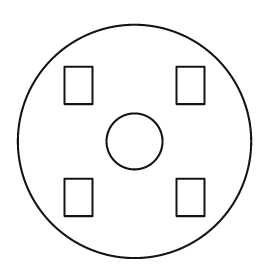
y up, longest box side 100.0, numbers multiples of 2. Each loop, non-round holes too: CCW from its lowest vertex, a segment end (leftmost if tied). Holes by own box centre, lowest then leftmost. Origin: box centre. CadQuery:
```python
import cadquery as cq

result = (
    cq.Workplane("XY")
    .moveTo(0.0, 0.0)
    .circle(50.0)
    .moveTo(-30.0, -32.0)
    .lineTo(-18.0, -32.0)
    .lineTo(-18.0, -16.0)
    .lineTo(-30.0, -16.0)
    .close()
    .moveTo(18.0, -32.0)
    .lineTo(30.0, -32.0)
    .lineTo(30.0, -16.0)
    .lineTo(18.0, -16.0)
    .close()
    .moveTo(0.0, 0.0)
    .circle(12.0)
    .moveTo(-30.0, 16.0)
    .lineTo(-18.0, 16.0)
    .lineTo(-18.0, 32.0)
    .lineTo(-30.0, 32.0)
    .close()
    .moveTo(18.0, 16.0)
    .lineTo(30.0, 16.0)
    .lineTo(30.0, 32.0)
    .lineTo(18.0, 32.0)
    .close()
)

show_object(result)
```